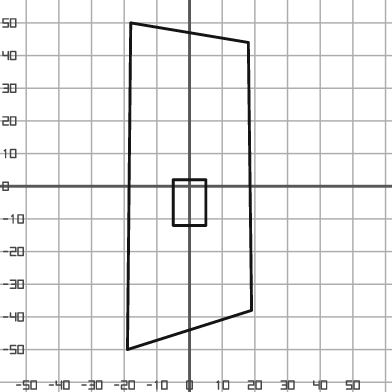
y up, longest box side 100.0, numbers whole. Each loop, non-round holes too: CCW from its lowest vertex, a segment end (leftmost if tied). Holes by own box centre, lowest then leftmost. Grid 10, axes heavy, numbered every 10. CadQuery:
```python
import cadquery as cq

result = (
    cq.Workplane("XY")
    .moveTo(-19.0, -50.0)
    .lineTo(19.0, -38.0)
    .lineTo(18.0, 44.0)
    .lineTo(-18.0, 50.0)
    .close()
    .moveTo(-5.0, -12.0)
    .lineTo(5.0, -12.0)
    .lineTo(5.0, 2.0)
    .lineTo(-5.0, 2.0)
    .close()
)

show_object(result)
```